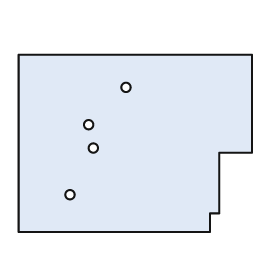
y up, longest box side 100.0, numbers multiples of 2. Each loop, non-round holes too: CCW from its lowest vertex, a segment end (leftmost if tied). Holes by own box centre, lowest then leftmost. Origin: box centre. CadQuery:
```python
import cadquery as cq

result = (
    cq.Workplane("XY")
    .moveTo(-50.0, -38.0)
    .lineTo(32.0, -38.0)
    .lineTo(32.0, -30.0)
    .lineTo(36.0, -30.0)
    .lineTo(36.0, -4.0)
    .lineTo(50.0, -4.0)
    .lineTo(50.0, 38.0)
    .lineTo(-50.0, 38.0)
    .close()
    .moveTo(-28.0, -22.0)
    .circle(2.0)
    .moveTo(-18.0, -2.0)
    .circle(2.0)
    .moveTo(-20.0, 8.0)
    .circle(2.0)
    .moveTo(-4.0, 24.0)
    .circle(2.0)
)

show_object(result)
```